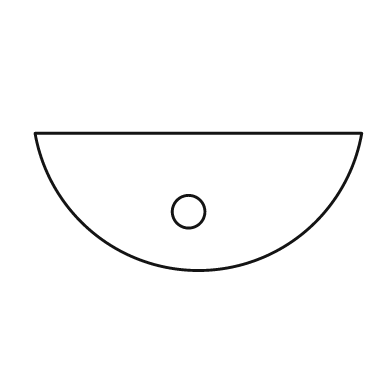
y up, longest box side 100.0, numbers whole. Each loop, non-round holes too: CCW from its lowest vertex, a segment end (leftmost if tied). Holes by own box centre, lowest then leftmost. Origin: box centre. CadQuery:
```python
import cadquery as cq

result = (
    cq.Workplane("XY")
    .moveTo(-50.0, 21.0)
    .threePointArc((0.0, -21.0), (50.0, 21.0))
    .close()
    .moveTo(-3.0, -3.0)
    .circle(5.0)
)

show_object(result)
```